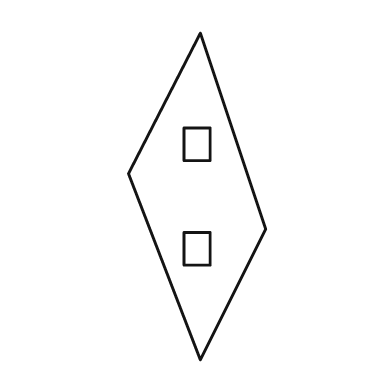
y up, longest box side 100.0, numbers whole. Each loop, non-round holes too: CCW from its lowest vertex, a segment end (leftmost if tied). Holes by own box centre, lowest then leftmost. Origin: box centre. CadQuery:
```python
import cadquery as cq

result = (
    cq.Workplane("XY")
    .moveTo(1.0, -50.0)
    .lineTo(21.0, -10.0)
    .lineTo(1.0, 50.0)
    .lineTo(-21.0, 7.0)
    .close()
    .moveTo(-4.0, -21.0)
    .lineTo(4.0, -21.0)
    .lineTo(4.0, -11.0)
    .lineTo(-4.0, -11.0)
    .close()
    .moveTo(-4.0, 11.0)
    .lineTo(4.0, 11.0)
    .lineTo(4.0, 21.0)
    .lineTo(-4.0, 21.0)
    .close()
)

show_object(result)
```